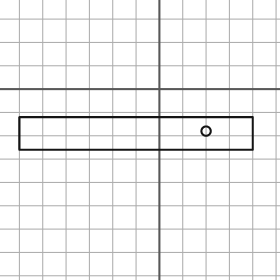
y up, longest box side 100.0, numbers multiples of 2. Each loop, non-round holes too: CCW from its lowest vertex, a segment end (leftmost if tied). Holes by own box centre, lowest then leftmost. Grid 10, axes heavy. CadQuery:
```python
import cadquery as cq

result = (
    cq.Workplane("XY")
    .moveTo(-60.0, -26.0)
    .lineTo(40.0, -26.0)
    .lineTo(40.0, -12.0)
    .lineTo(-60.0, -12.0)
    .close()
    .moveTo(20.0, -18.0)
    .circle(2.0)
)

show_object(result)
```